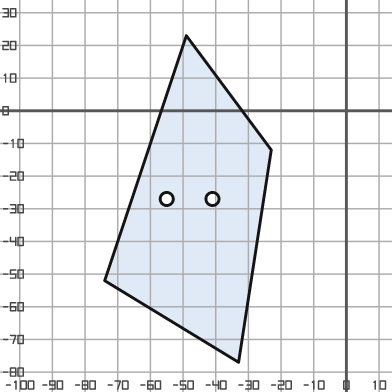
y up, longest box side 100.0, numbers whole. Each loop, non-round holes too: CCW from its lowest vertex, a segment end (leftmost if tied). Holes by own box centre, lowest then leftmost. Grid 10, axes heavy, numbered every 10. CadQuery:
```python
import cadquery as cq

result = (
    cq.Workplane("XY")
    .moveTo(-33.0, -77.0)
    .lineTo(-23.0, -12.0)
    .lineTo(-49.0, 23.0)
    .lineTo(-74.0, -52.0)
    .close()
    .moveTo(-55.0, -27.0)
    .circle(2.0)
    .moveTo(-41.0, -27.0)
    .circle(2.0)
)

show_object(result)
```